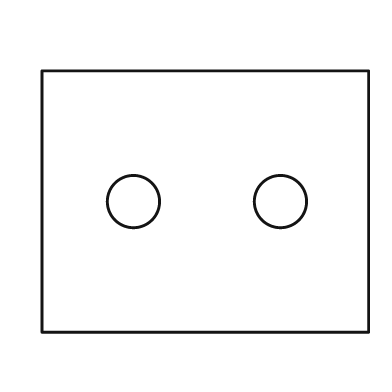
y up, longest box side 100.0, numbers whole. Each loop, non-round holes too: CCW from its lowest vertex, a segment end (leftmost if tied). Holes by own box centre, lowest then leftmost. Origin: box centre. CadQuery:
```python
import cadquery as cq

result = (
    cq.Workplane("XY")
    .moveTo(-50.0, -40.0)
    .lineTo(50.0, -40.0)
    .lineTo(50.0, 40.0)
    .lineTo(-50.0, 40.0)
    .close()
    .moveTo(-22.0, 0.0)
    .circle(8.0)
    .moveTo(23.0, 0.0)
    .circle(8.0)
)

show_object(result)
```